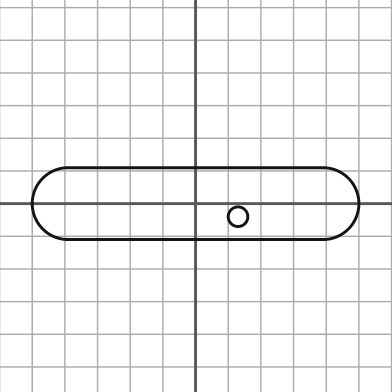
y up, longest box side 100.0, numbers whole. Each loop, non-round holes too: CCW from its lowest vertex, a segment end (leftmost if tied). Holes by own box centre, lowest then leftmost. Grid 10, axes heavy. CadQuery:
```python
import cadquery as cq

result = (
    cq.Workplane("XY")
    .moveTo(-39.0, -11.0)
    .lineTo(39.0, -11.0)
    .threePointArc((50.0, 0.0), (39.0, 11.0))
    .lineTo(-39.0, 11.0)
    .threePointArc((-50.0, 0.0), (-39.0, -11.0))
    .close()
    .moveTo(13.0, -4.0)
    .circle(3.0)
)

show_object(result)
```